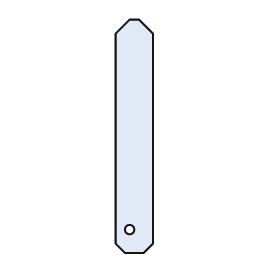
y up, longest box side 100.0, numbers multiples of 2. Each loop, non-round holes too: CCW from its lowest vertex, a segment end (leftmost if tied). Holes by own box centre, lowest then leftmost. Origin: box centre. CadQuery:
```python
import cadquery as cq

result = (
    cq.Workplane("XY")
    .moveTo(-4.0, -50.0)
    .lineTo(4.0, -50.0)
    .lineTo(8.0, -46.0)
    .lineTo(8.0, 44.0)
    .lineTo(2.0, 50.0)
    .lineTo(-2.0, 50.0)
    .lineTo(-8.0, 44.0)
    .lineTo(-8.0, -46.0)
    .close()
    .moveTo(-2.0, -40.0)
    .circle(2.0)
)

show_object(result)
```